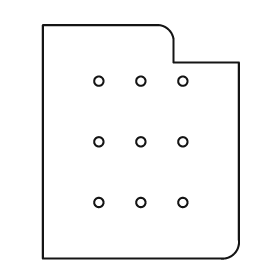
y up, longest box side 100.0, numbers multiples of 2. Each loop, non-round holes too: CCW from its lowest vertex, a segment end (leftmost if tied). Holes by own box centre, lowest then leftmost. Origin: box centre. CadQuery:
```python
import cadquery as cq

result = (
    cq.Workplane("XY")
    .moveTo(-42.0, -50.0)
    .lineTo(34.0, -50.0)
    .threePointArc((40.0, -48.0), (42.0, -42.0))
    .lineTo(42.0, 34.0)
    .lineTo(14.0, 34.0)
    .lineTo(14.0, 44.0)
    .threePointArc((12.0, 48.0), (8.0, 50.0))
    .lineTo(-42.0, 50.0)
    .close()
    .moveTo(-18.0, -26.0)
    .circle(2.0)
    .moveTo(0.0, -26.0)
    .circle(2.0)
    .moveTo(18.0, -26.0)
    .circle(2.0)
    .moveTo(-18.0, 0.0)
    .circle(2.0)
    .moveTo(0.0, 0.0)
    .circle(2.0)
    .moveTo(18.0, 0.0)
    .circle(2.0)
    .moveTo(-18.0, 26.0)
    .circle(2.0)
    .moveTo(0.0, 26.0)
    .circle(2.0)
    .moveTo(18.0, 26.0)
    .circle(2.0)
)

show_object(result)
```